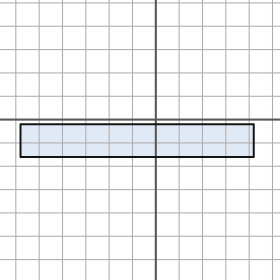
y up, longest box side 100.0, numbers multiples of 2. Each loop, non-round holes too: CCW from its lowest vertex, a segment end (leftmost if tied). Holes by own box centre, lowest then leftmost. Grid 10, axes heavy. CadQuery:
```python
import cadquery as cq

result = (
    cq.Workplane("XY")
    .moveTo(-58.0, -16.0)
    .lineTo(42.0, -16.0)
    .lineTo(42.0, -2.0)
    .lineTo(-58.0, -2.0)
    .close()
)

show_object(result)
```